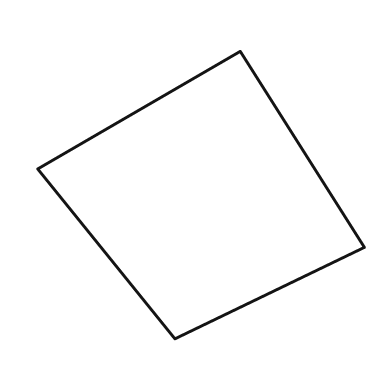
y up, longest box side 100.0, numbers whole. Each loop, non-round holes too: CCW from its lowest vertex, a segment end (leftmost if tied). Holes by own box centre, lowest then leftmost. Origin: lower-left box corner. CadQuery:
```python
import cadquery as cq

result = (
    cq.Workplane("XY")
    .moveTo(42.0, 0.0)
    .lineTo(100.0, 28.0)
    .lineTo(62.0, 88.0)
    .lineTo(0.0, 52.0)
    .close()
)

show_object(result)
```